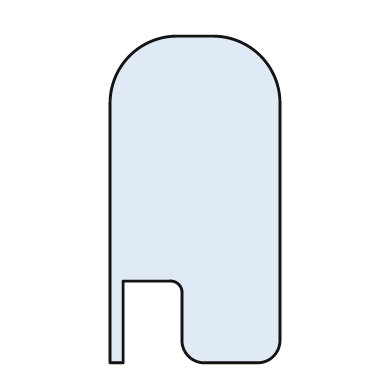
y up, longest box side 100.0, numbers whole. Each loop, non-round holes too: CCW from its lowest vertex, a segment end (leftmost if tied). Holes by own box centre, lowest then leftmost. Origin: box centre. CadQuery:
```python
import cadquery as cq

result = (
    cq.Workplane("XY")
    .moveTo(-26.0, -50.0)
    .lineTo(-22.0, -50.0)
    .lineTo(-22.0, -25.0)
    .lineTo(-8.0, -25.0)
    .threePointArc((-5.0, -26.0), (-4.0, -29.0))
    .lineTo(-4.0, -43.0)
    .threePointArc((-2.0, -48.0), (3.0, -50.0))
    .lineTo(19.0, -50.0)
    .threePointArc((24.0, -48.0), (26.0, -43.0))
    .lineTo(26.0, 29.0)
    .threePointArc((20.0, 44.0), (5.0, 50.0))
    .lineTo(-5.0, 50.0)
    .threePointArc((-20.0, 44.0), (-26.0, 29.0))
    .close()
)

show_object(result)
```